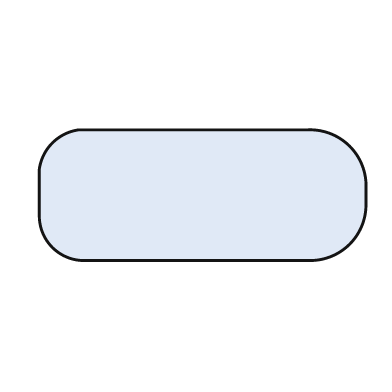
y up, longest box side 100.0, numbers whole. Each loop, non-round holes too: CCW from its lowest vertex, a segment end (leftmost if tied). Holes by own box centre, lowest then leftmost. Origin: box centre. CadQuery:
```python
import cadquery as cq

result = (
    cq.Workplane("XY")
    .moveTo(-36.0, -20.0)
    .lineTo(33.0, -20.0)
    .threePointArc((45.0, -15.0), (50.0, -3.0))
    .lineTo(50.0, 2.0)
    .threePointArc((45.0, 15.0), (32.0, 20.0))
    .lineTo(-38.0, 20.0)
    .threePointArc((-46.0, 16.0), (-50.0, 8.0))
    .lineTo(-50.0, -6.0)
    .threePointArc((-46.0, -16.0), (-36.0, -20.0))
    .close()
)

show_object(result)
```